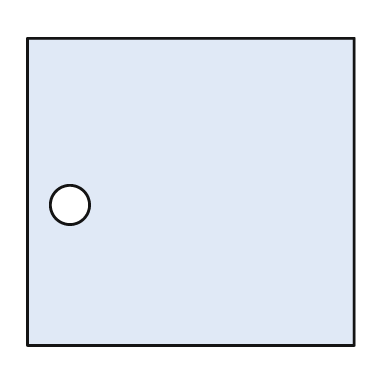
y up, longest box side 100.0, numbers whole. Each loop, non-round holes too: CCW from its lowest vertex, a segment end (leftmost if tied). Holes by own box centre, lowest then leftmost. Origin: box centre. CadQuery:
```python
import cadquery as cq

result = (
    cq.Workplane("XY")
    .moveTo(-50.0, -47.0)
    .lineTo(50.0, -47.0)
    .lineTo(50.0, 47.0)
    .lineTo(-50.0, 47.0)
    .close()
    .moveTo(-37.0, -4.0)
    .circle(6.0)
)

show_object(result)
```